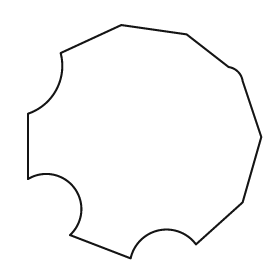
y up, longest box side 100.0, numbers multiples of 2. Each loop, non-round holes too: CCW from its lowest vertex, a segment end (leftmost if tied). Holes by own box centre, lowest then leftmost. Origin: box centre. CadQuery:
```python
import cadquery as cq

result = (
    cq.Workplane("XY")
    .moveTo(-6.0, -50.0)
    .threePointArc((6.0, -38.0), (22.0, -44.0))
    .lineTo(42.0, -26.0)
    .lineTo(50.0, 2.0)
    .lineTo(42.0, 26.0)
    .threePointArc((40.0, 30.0), (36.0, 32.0))
    .lineTo(18.0, 46.0)
    .lineTo(-10.0, 50.0)
    .lineTo(-36.0, 38.0)
    .threePointArc((-38.0, 22.0), (-50.0, 12.0))
    .lineTo(-50.0, -16.0)
    .threePointArc((-30.0, -20.0), (-32.0, -40.0))
    .close()
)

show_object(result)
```